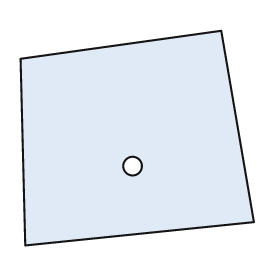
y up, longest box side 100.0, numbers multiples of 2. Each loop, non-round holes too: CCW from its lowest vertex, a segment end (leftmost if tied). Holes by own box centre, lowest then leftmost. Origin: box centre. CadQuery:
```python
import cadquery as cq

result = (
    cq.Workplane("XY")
    .moveTo(-48.0, -46.0)
    .lineTo(50.0, -36.0)
    .lineTo(36.0, 46.0)
    .lineTo(-50.0, 34.0)
    .close()
    .moveTo(-2.0, -12.0)
    .circle(4.0)
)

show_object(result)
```